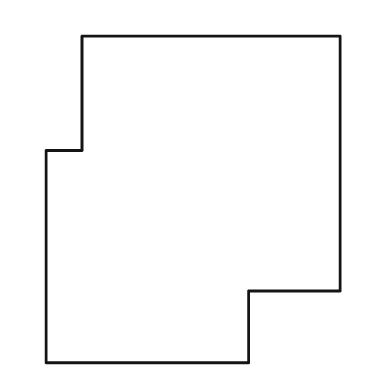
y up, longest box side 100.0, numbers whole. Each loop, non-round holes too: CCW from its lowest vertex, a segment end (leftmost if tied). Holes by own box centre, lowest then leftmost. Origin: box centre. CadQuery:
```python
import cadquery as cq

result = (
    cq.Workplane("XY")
    .moveTo(-45.0, -50.0)
    .lineTo(17.0, -50.0)
    .lineTo(17.0, -28.0)
    .lineTo(45.0, -28.0)
    .lineTo(45.0, 50.0)
    .lineTo(-34.0, 50.0)
    .lineTo(-34.0, 15.0)
    .lineTo(-45.0, 15.0)
    .close()
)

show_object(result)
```